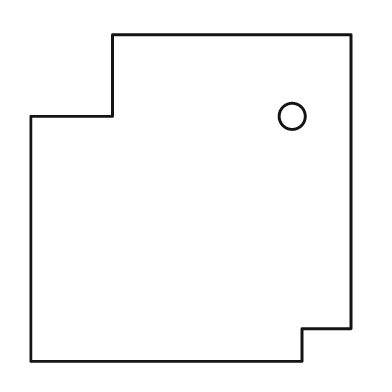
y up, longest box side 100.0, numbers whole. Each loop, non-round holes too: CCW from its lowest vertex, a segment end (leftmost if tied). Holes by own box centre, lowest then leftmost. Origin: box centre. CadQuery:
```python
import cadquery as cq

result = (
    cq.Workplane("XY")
    .moveTo(-49.0, -50.0)
    .lineTo(34.0, -50.0)
    .lineTo(34.0, -40.0)
    .lineTo(49.0, -40.0)
    .lineTo(49.0, 50.0)
    .lineTo(-24.0, 50.0)
    .lineTo(-24.0, 25.0)
    .lineTo(-49.0, 25.0)
    .close()
    .moveTo(31.0, 25.0)
    .circle(4.0)
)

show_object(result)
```